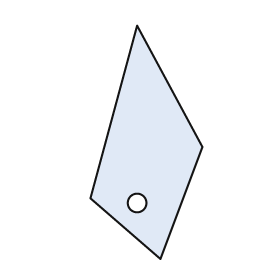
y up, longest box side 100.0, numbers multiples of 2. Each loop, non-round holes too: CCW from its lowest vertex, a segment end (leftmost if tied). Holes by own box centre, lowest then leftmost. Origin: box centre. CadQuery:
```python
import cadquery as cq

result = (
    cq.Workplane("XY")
    .moveTo(6.0, -50.0)
    .lineTo(24.0, -2.0)
    .lineTo(-4.0, 50.0)
    .lineTo(-24.0, -24.0)
    .close()
    .moveTo(-4.0, -26.0)
    .circle(4.0)
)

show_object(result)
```